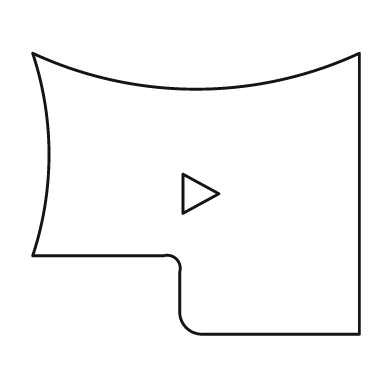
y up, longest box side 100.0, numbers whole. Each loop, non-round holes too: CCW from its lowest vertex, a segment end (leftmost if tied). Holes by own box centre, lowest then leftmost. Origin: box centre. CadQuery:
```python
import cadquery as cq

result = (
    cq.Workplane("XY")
    .moveTo(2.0, -43.0)
    .lineTo(50.0, -43.0)
    .lineTo(50.0, 43.0)
    .threePointArc((0.0, 32.0), (-50.0, 43.0))
    .threePointArc((-45.0, 12.0), (-50.0, -19.0))
    .lineTo(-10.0, -19.0)
    .threePointArc((-6.0, -20.0), (-5.0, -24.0))
    .lineTo(-5.0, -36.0)
    .threePointArc((-3.0, -41.0), (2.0, -43.0))
    .close()
    .moveTo(-4.0, -6.0)
    .lineTo(7.0, 0.0)
    .lineTo(-4.0, 6.0)
    .close()
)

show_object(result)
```